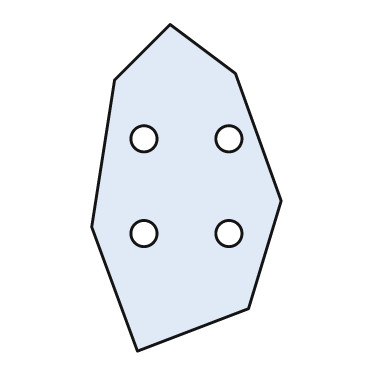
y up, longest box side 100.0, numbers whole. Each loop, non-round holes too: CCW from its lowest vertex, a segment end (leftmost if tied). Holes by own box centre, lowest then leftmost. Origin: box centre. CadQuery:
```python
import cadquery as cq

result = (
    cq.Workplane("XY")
    .moveTo(-15.0, -50.0)
    .lineTo(19.0, -37.0)
    .lineTo(29.0, -4.0)
    .lineTo(15.0, 35.0)
    .lineTo(-5.0, 50.0)
    .lineTo(-22.0, 33.0)
    .lineTo(-29.0, -12.0)
    .close()
    .moveTo(-13.0, -14.0)
    .circle(4.0)
    .moveTo(13.0, -14.0)
    .circle(4.0)
    .moveTo(-13.0, 15.0)
    .circle(4.0)
    .moveTo(13.0, 15.0)
    .circle(4.0)
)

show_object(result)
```